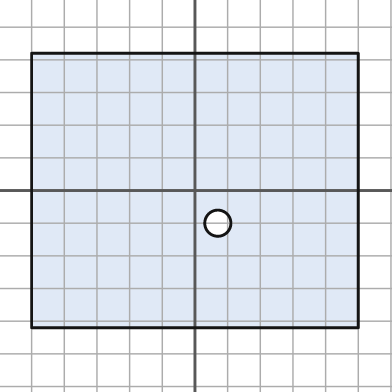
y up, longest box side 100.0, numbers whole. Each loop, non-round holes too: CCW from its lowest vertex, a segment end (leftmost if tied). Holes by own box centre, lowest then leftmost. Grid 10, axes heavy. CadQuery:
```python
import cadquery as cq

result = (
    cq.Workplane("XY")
    .moveTo(-50.0, -42.0)
    .lineTo(50.0, -42.0)
    .lineTo(50.0, 42.0)
    .lineTo(-50.0, 42.0)
    .close()
    .moveTo(7.0, -10.0)
    .circle(4.0)
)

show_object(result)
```